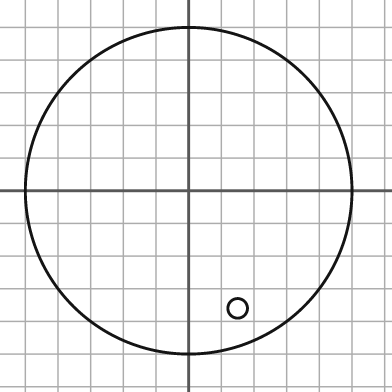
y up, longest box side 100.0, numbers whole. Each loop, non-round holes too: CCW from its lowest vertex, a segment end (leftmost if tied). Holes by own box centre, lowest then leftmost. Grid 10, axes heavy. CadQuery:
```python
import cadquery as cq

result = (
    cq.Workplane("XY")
    .moveTo(0.0, 0.0)
    .circle(50.0)
    .moveTo(15.0, -36.0)
    .circle(3.0)
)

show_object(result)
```